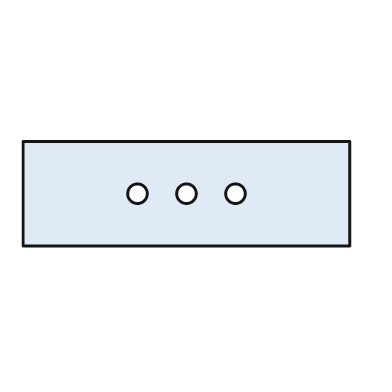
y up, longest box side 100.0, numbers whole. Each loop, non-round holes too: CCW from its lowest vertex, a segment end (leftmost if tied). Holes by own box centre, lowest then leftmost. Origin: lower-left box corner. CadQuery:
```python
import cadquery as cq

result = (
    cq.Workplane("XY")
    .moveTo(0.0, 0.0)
    .lineTo(100.0, 0.0)
    .lineTo(100.0, 32.0)
    .lineTo(0.0, 32.0)
    .close()
    .moveTo(35.0, 16.0)
    .circle(3.0)
    .moveTo(50.0, 16.0)
    .circle(3.0)
    .moveTo(65.0, 16.0)
    .circle(3.0)
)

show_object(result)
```